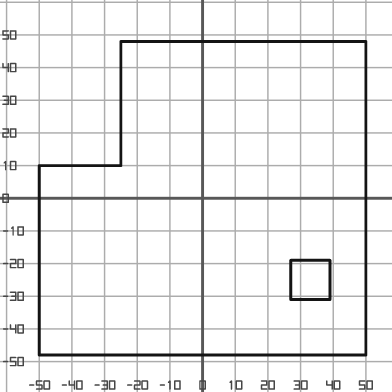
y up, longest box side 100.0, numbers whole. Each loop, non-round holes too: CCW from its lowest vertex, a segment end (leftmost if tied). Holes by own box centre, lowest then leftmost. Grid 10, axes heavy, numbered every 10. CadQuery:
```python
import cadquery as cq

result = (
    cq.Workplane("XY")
    .moveTo(-50.0, -48.0)
    .lineTo(50.0, -48.0)
    .lineTo(50.0, 48.0)
    .lineTo(-25.0, 48.0)
    .lineTo(-25.0, 10.0)
    .lineTo(-50.0, 10.0)
    .close()
    .moveTo(27.0, -31.0)
    .lineTo(39.0, -31.0)
    .lineTo(39.0, -19.0)
    .lineTo(27.0, -19.0)
    .close()
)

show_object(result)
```